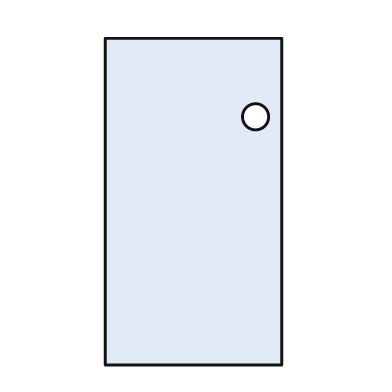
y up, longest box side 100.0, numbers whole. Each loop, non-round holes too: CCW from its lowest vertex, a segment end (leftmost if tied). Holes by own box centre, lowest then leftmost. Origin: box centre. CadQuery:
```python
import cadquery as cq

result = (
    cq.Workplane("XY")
    .moveTo(-27.0, -50.0)
    .lineTo(27.0, -50.0)
    .lineTo(27.0, 50.0)
    .lineTo(-27.0, 50.0)
    .close()
    .moveTo(19.0, 26.0)
    .circle(4.0)
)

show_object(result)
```